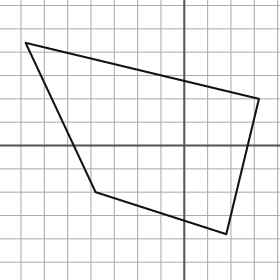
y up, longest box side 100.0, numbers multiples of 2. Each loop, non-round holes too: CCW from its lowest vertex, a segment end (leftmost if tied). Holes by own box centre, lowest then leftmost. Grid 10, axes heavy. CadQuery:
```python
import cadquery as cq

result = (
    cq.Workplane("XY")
    .moveTo(18.0, -38.0)
    .lineTo(32.0, 20.0)
    .lineTo(-68.0, 44.0)
    .lineTo(-38.0, -20.0)
    .close()
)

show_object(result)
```